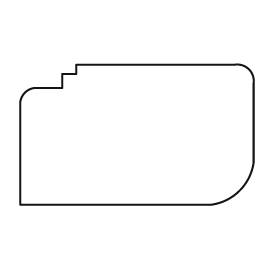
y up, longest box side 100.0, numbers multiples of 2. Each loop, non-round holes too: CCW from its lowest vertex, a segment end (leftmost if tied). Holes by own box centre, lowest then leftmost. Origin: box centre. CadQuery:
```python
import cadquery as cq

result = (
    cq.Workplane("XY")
    .moveTo(-50.0, -30.0)
    .lineTo(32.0, -30.0)
    .threePointArc((44.0, -24.0), (50.0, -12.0))
    .lineTo(50.0, 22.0)
    .threePointArc((48.0, 28.0), (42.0, 30.0))
    .lineTo(-26.0, 30.0)
    .lineTo(-26.0, 26.0)
    .lineTo(-32.0, 26.0)
    .lineTo(-32.0, 20.0)
    .lineTo(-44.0, 20.0)
    .threePointArc((-48.0, 18.0), (-50.0, 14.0))
    .close()
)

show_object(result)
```